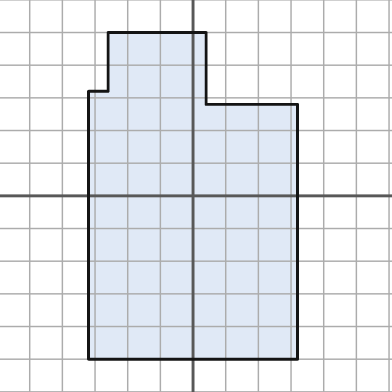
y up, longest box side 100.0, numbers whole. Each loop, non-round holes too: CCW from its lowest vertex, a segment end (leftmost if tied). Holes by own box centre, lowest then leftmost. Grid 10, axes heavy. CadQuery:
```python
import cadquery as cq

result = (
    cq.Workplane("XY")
    .moveTo(-32.0, -50.0)
    .lineTo(32.0, -50.0)
    .lineTo(32.0, 28.0)
    .lineTo(4.0, 28.0)
    .lineTo(4.0, 50.0)
    .lineTo(-26.0, 50.0)
    .lineTo(-26.0, 32.0)
    .lineTo(-32.0, 32.0)
    .close()
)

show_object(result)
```